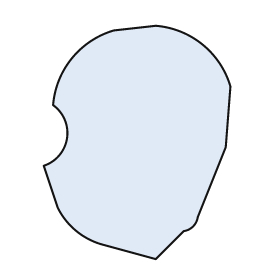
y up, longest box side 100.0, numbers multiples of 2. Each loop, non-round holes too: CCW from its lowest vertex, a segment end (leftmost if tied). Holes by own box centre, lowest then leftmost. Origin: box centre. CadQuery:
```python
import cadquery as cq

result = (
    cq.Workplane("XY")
    .moveTo(8.0, -50.0)
    .lineTo(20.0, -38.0)
    .threePointArc((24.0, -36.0), (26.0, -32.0))
    .lineTo(38.0, -2.0)
    .lineTo(40.0, 24.0)
    .threePointArc((28.0, 42.0), (8.0, 50.0))
    .lineTo(-10.0, 48.0)
    .threePointArc((-28.0, 36.0), (-36.0, 16.0))
    .threePointArc((-30.0, 2.0), (-40.0, -10.0))
    .lineTo(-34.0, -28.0)
    .threePointArc((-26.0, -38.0), (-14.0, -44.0))
    .close()
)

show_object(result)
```